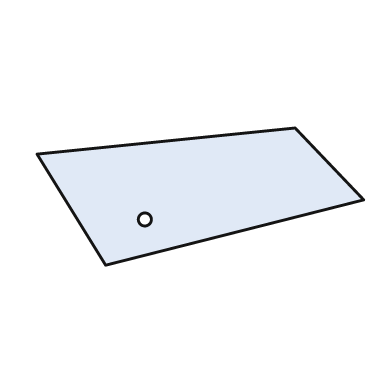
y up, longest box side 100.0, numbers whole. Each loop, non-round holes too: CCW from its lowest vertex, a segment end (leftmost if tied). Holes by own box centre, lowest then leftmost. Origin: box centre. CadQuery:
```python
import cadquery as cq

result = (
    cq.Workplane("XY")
    .moveTo(-29.0, -21.0)
    .lineTo(50.0, -1.0)
    .lineTo(29.0, 21.0)
    .lineTo(-50.0, 13.0)
    .close()
    .moveTo(-17.0, -7.0)
    .circle(2.0)
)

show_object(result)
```